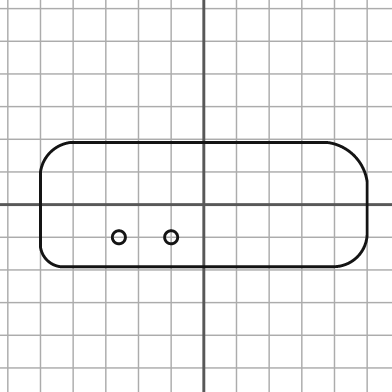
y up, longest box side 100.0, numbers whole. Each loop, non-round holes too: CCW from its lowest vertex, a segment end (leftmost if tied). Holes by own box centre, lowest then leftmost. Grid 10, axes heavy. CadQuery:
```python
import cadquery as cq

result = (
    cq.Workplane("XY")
    .moveTo(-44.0, -19.0)
    .lineTo(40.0, -19.0)
    .threePointArc((47.0, -16.0), (50.0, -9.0))
    .lineTo(50.0, 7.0)
    .threePointArc((46.0, 15.0), (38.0, 19.0))
    .lineTo(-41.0, 19.0)
    .threePointArc((-47.0, 16.0), (-50.0, 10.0))
    .lineTo(-50.0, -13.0)
    .threePointArc((-48.0, -17.0), (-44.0, -19.0))
    .close()
    .moveTo(-26.0, -10.0)
    .circle(2.0)
    .moveTo(-10.0, -10.0)
    .circle(2.0)
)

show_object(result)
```